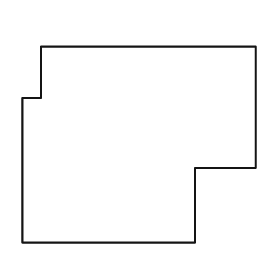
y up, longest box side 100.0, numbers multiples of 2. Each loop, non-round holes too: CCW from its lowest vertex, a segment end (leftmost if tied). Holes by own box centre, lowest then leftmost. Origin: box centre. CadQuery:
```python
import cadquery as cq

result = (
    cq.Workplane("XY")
    .moveTo(-50.0, -42.0)
    .lineTo(24.0, -42.0)
    .lineTo(24.0, -10.0)
    .lineTo(50.0, -10.0)
    .lineTo(50.0, 42.0)
    .lineTo(-42.0, 42.0)
    .lineTo(-42.0, 20.0)
    .lineTo(-50.0, 20.0)
    .close()
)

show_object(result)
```